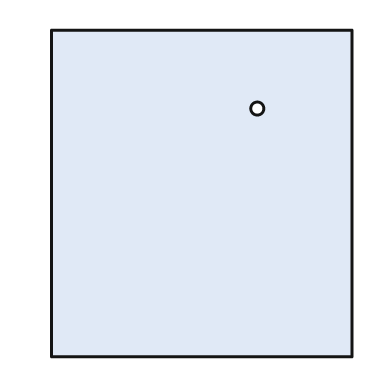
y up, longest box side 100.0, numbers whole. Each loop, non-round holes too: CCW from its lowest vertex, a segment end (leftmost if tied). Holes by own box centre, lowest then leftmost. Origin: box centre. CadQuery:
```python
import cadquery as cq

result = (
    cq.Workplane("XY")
    .moveTo(-46.0, -50.0)
    .lineTo(46.0, -50.0)
    .lineTo(46.0, 50.0)
    .lineTo(-46.0, 50.0)
    .close()
    .moveTo(17.0, 26.0)
    .circle(2.0)
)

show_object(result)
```